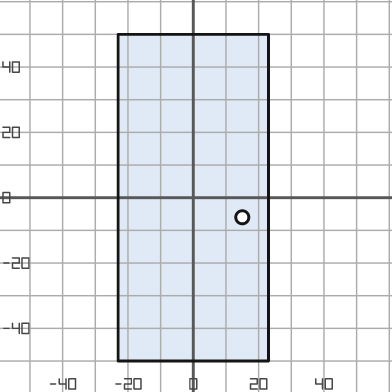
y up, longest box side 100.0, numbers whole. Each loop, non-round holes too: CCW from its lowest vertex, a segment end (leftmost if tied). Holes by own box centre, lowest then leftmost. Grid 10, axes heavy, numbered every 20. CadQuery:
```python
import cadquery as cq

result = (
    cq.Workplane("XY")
    .moveTo(-23.0, -50.0)
    .lineTo(23.0, -50.0)
    .lineTo(23.0, 50.0)
    .lineTo(-23.0, 50.0)
    .close()
    .moveTo(15.0, -6.0)
    .circle(2.0)
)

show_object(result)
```